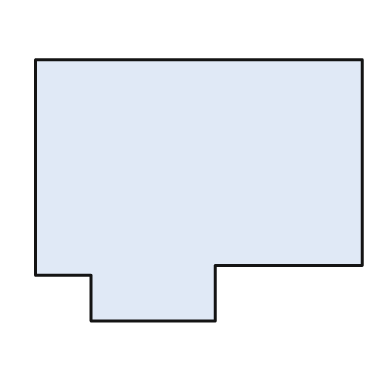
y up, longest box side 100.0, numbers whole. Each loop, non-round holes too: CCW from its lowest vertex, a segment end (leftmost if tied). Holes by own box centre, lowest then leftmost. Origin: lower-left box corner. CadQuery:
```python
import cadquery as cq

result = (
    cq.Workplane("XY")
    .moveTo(17.0, 0.0)
    .lineTo(55.0, 0.0)
    .lineTo(55.0, 17.0)
    .lineTo(100.0, 17.0)
    .lineTo(100.0, 80.0)
    .lineTo(0.0, 80.0)
    .lineTo(0.0, 14.0)
    .lineTo(17.0, 14.0)
    .close()
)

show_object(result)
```